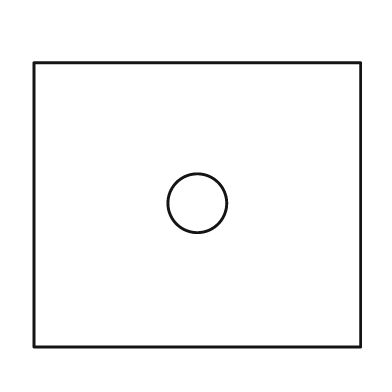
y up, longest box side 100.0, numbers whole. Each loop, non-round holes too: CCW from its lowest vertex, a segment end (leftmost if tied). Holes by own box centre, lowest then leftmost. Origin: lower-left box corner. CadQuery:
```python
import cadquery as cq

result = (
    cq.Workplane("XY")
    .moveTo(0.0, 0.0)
    .lineTo(100.0, 0.0)
    .lineTo(100.0, 87.0)
    .lineTo(0.0, 87.0)
    .close()
    .moveTo(50.0, 44.0)
    .circle(9.0)
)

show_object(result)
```